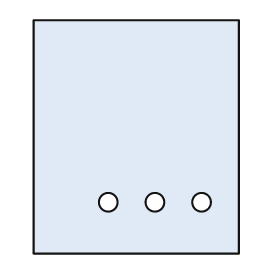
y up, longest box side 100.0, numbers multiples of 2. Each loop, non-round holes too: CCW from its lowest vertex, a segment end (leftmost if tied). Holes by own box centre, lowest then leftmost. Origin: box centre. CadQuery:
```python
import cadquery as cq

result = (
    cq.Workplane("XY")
    .moveTo(-44.0, -50.0)
    .lineTo(44.0, -50.0)
    .lineTo(44.0, 50.0)
    .lineTo(-44.0, 50.0)
    .close()
    .moveTo(-12.0, -28.0)
    .circle(4.0)
    .moveTo(8.0, -28.0)
    .circle(4.0)
    .moveTo(28.0, -28.0)
    .circle(4.0)
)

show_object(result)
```